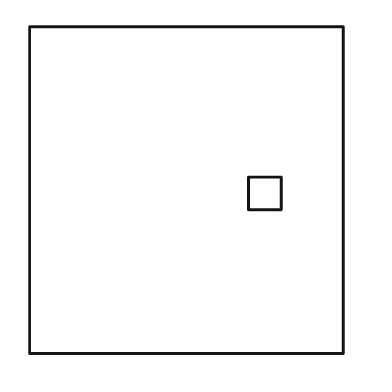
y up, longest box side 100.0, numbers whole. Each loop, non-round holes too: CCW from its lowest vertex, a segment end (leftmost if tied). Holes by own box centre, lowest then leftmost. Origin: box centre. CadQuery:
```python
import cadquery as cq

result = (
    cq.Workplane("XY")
    .moveTo(-48.0, -50.0)
    .lineTo(48.0, -50.0)
    .lineTo(48.0, 50.0)
    .lineTo(-48.0, 50.0)
    .close()
    .moveTo(19.0, -6.0)
    .lineTo(29.0, -6.0)
    .lineTo(29.0, 4.0)
    .lineTo(19.0, 4.0)
    .close()
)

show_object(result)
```